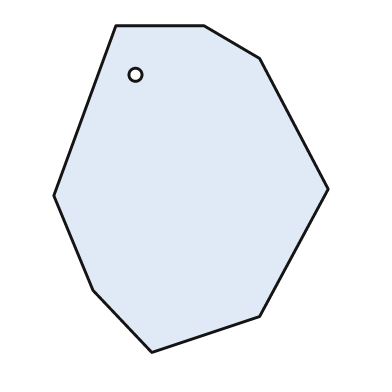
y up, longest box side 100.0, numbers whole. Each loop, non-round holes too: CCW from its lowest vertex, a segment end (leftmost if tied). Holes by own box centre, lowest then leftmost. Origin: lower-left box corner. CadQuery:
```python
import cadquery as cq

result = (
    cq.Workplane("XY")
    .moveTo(30.0, 0.0)
    .lineTo(63.0, 11.0)
    .lineTo(84.0, 50.0)
    .lineTo(63.0, 90.0)
    .lineTo(46.0, 100.0)
    .lineTo(19.0, 100.0)
    .lineTo(0.0, 48.0)
    .lineTo(12.0, 19.0)
    .close()
    .moveTo(25.0, 85.0)
    .circle(2.0)
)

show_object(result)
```